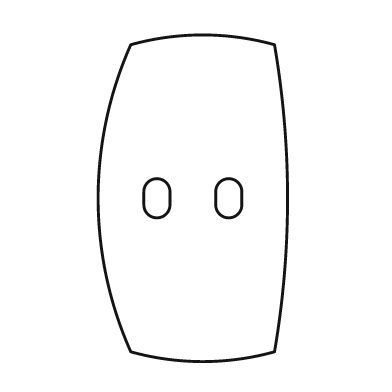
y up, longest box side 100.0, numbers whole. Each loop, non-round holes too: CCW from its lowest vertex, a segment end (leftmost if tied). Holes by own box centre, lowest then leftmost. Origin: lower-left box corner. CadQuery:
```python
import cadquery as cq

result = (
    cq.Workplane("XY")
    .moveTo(10.0, 3.0)
    .threePointArc((32.0, 0.0), (54.0, 3.0))
    .threePointArc((58.0, 50.0), (54.0, 97.0))
    .threePointArc((32.0, 100.0), (10.0, 97.0))
    .threePointArc((0.0, 50.0), (10.0, 3.0))
    .close()
    .moveTo(14.0, 48.0)
    .threePointArc((18.0, 44.0), (22.0, 48.0))
    .lineTo(22.0, 52.0)
    .threePointArc((18.0, 56.0), (14.0, 52.0))
    .close()
    .moveTo(36.0, 48.0)
    .threePointArc((40.0, 44.0), (44.0, 48.0))
    .lineTo(44.0, 52.0)
    .threePointArc((40.0, 56.0), (36.0, 52.0))
    .close()
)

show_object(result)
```